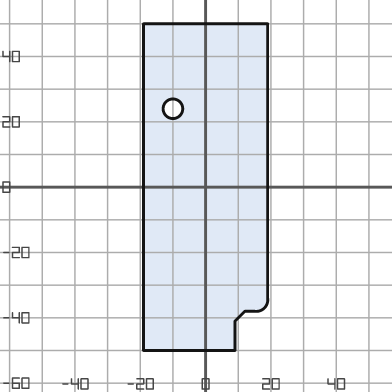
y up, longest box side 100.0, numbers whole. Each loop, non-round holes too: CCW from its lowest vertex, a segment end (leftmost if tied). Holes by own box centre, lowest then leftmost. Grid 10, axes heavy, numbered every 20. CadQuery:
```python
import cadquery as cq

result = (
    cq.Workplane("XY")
    .moveTo(-19.0, -50.0)
    .lineTo(9.0, -50.0)
    .lineTo(9.0, -41.0)
    .lineTo(12.0, -38.0)
    .lineTo(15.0, -38.0)
    .threePointArc((18.0, -37.0), (19.0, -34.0))
    .lineTo(19.0, 50.0)
    .lineTo(-19.0, 50.0)
    .close()
    .moveTo(-10.0, 24.0)
    .circle(3.0)
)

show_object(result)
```